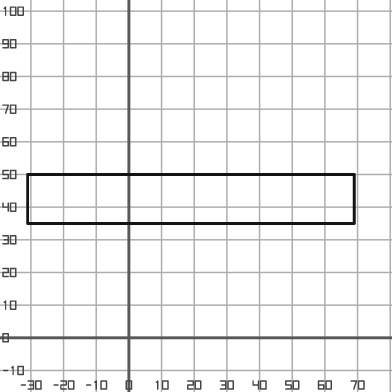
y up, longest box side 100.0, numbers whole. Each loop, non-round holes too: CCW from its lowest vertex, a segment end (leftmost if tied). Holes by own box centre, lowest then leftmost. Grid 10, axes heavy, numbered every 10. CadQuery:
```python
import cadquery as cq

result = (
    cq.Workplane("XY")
    .moveTo(-31.0, 35.0)
    .lineTo(69.0, 35.0)
    .lineTo(69.0, 50.0)
    .lineTo(-31.0, 50.0)
    .close()
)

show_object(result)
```